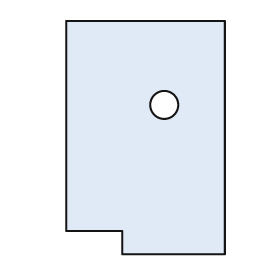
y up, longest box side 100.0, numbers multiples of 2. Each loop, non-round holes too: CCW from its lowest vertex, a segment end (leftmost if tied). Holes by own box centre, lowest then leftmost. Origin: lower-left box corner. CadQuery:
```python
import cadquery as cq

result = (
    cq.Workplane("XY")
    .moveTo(24.0, 0.0)
    .lineTo(68.0, 0.0)
    .lineTo(68.0, 100.0)
    .lineTo(0.0, 100.0)
    .lineTo(0.0, 10.0)
    .lineTo(24.0, 10.0)
    .close()
    .moveTo(42.0, 64.0)
    .circle(6.0)
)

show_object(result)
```